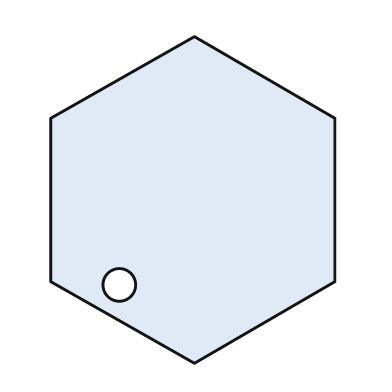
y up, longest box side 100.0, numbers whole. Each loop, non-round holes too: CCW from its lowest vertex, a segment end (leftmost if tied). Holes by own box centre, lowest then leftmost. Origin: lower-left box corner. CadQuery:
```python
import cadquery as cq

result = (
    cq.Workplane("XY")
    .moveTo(44.0, 0.0)
    .lineTo(87.0, 25.0)
    .lineTo(87.0, 75.0)
    .lineTo(44.0, 100.0)
    .lineTo(0.0, 75.0)
    .lineTo(0.0, 25.0)
    .close()
    .moveTo(21.0, 24.0)
    .circle(5.0)
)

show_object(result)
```